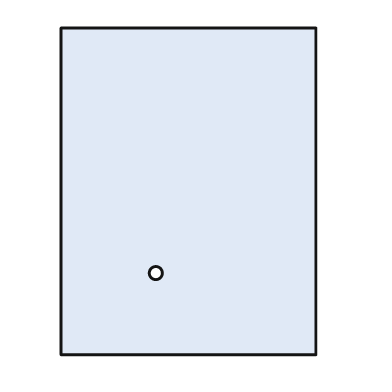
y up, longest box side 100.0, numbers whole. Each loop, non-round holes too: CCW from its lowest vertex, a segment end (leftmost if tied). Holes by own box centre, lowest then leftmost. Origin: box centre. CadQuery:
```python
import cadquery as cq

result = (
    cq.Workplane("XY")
    .moveTo(-39.0, -50.0)
    .lineTo(39.0, -50.0)
    .lineTo(39.0, 50.0)
    .lineTo(-39.0, 50.0)
    .close()
    .moveTo(-10.0, -25.0)
    .circle(2.0)
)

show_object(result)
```